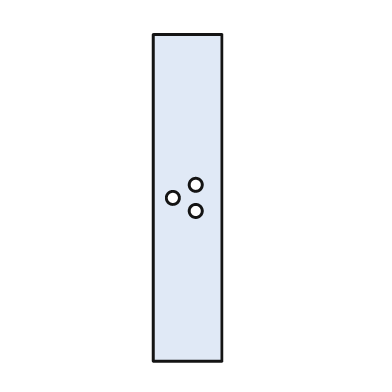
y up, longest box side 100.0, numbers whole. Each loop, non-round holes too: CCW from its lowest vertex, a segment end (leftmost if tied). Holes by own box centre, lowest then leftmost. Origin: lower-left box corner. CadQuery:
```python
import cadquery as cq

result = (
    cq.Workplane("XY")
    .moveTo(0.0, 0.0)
    .lineTo(21.0, 0.0)
    .lineTo(21.0, 100.0)
    .lineTo(0.0, 100.0)
    .close()
    .moveTo(13.0, 46.0)
    .circle(2.0)
    .moveTo(6.0, 50.0)
    .circle(2.0)
    .moveTo(13.0, 54.0)
    .circle(2.0)
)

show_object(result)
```